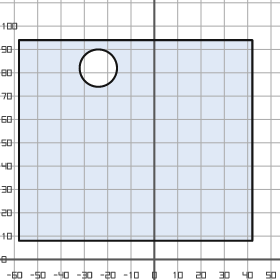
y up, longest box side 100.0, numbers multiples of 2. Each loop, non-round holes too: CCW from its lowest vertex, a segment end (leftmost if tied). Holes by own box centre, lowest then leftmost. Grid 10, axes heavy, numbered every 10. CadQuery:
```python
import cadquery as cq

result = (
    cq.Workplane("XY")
    .moveTo(-58.0, 8.0)
    .lineTo(42.0, 8.0)
    .lineTo(42.0, 94.0)
    .lineTo(-58.0, 94.0)
    .close()
    .moveTo(-24.0, 82.0)
    .circle(8.0)
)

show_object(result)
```